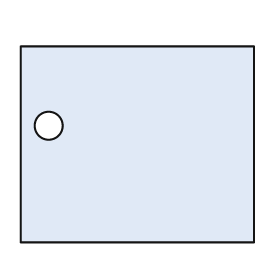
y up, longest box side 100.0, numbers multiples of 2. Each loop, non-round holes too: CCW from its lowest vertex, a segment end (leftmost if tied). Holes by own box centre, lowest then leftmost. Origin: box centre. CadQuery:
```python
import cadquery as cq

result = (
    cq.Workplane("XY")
    .moveTo(-50.0, -42.0)
    .lineTo(50.0, -42.0)
    .lineTo(50.0, 42.0)
    .lineTo(-50.0, 42.0)
    .close()
    .moveTo(-38.0, 8.0)
    .circle(6.0)
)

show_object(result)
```